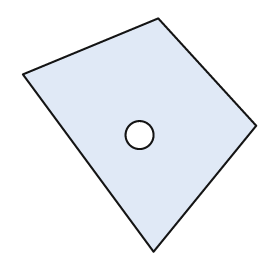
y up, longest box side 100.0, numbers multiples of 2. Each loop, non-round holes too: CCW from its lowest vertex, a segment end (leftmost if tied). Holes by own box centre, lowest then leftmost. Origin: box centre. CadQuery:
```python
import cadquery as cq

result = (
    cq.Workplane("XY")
    .moveTo(6.0, -50.0)
    .lineTo(50.0, 4.0)
    .lineTo(8.0, 50.0)
    .lineTo(-50.0, 26.0)
    .close()
    .moveTo(0.0, 0.0)
    .circle(6.0)
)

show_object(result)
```